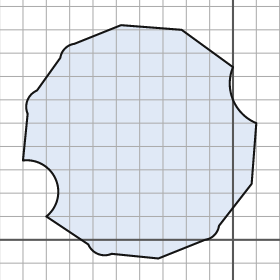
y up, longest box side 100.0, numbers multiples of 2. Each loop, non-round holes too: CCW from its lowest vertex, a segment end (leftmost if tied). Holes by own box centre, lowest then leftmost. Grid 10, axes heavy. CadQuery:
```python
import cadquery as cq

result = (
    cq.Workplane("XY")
    .moveTo(-32.0, -8.0)
    .lineTo(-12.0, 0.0)
    .threePointArc((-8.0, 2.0), (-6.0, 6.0))
    .lineTo(8.0, 24.0)
    .lineTo(10.0, 50.0)
    .threePointArc((0.0, 60.0), (0.0, 74.0))
    .lineTo(-22.0, 90.0)
    .lineTo(-48.0, 92.0)
    .lineTo(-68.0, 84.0)
    .threePointArc((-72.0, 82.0), (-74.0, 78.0))
    .lineTo(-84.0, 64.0)
    .threePointArc((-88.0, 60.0), (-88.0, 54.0))
    .lineTo(-90.0, 34.0)
    .threePointArc((-76.0, 26.0), (-80.0, 10.0))
    .lineTo(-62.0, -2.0)
    .threePointArc((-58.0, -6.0), (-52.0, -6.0))
    .close()
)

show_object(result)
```